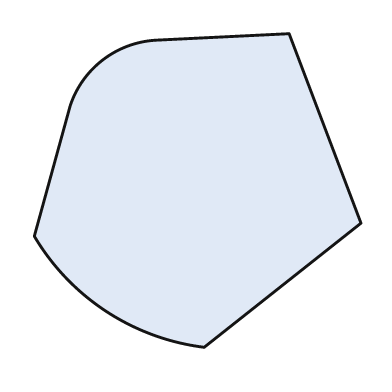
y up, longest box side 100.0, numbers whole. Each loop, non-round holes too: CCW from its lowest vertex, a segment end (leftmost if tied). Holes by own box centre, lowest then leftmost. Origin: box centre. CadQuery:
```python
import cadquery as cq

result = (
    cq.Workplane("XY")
    .moveTo(2.0, -48.0)
    .lineTo(50.0, -10.0)
    .lineTo(28.0, 48.0)
    .lineTo(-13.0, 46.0)
    .threePointArc((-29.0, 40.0), (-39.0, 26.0))
    .lineTo(-50.0, -14.0)
    .threePointArc((-28.0, -37.0), (2.0, -48.0))
    .close()
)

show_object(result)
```